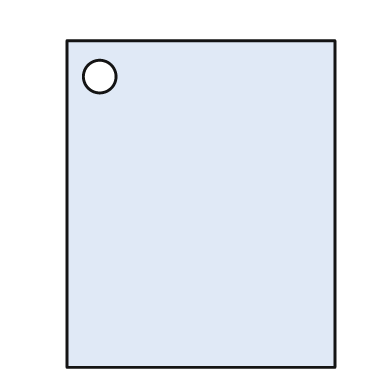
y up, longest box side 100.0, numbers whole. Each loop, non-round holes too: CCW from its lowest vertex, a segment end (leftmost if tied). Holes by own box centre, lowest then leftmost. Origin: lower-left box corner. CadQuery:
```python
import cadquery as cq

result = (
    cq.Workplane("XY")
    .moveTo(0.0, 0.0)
    .lineTo(82.0, 0.0)
    .lineTo(82.0, 100.0)
    .lineTo(0.0, 100.0)
    .close()
    .moveTo(10.0, 89.0)
    .circle(5.0)
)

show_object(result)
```